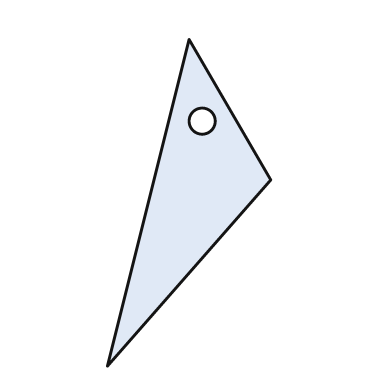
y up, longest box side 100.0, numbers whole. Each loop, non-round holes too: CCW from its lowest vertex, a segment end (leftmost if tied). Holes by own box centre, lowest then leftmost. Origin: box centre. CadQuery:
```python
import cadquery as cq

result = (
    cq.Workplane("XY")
    .moveTo(-25.0, -50.0)
    .lineTo(25.0, 7.0)
    .lineTo(0.0, 50.0)
    .close()
    .moveTo(4.0, 25.0)
    .circle(4.0)
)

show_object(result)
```